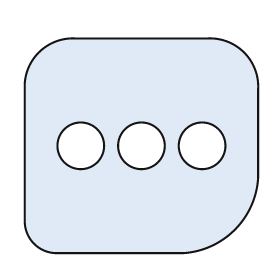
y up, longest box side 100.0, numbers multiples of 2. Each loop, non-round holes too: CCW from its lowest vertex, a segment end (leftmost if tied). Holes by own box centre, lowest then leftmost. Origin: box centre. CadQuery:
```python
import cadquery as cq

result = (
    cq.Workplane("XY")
    .moveTo(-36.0, -46.0)
    .lineTo(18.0, -46.0)
    .threePointArc((40.0, -36.0), (50.0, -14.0))
    .lineTo(50.0, 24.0)
    .threePointArc((44.0, 40.0), (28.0, 46.0))
    .lineTo(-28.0, 46.0)
    .threePointArc((-44.0, 40.0), (-50.0, 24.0))
    .lineTo(-50.0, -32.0)
    .threePointArc((-46.0, -42.0), (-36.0, -46.0))
    .close()
    .moveTo(-26.0, 0.0)
    .circle(10.0)
    .moveTo(0.0, 0.0)
    .circle(10.0)
    .moveTo(26.0, 0.0)
    .circle(10.0)
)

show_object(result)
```